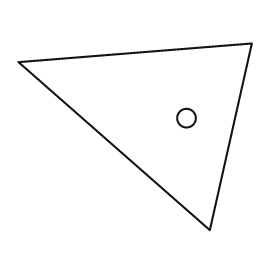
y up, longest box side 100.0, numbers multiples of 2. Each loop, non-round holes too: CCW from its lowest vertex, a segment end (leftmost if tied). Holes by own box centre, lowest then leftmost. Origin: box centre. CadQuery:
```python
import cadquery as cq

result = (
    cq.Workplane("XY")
    .moveTo(32.0, -40.0)
    .lineTo(50.0, 40.0)
    .lineTo(-50.0, 32.0)
    .close()
    .moveTo(22.0, 8.0)
    .circle(4.0)
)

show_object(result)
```